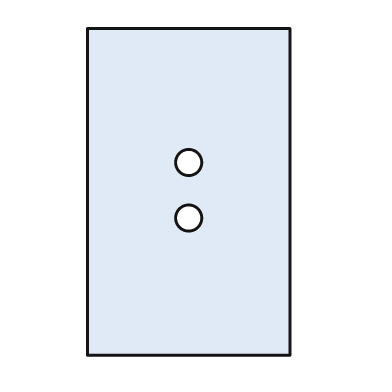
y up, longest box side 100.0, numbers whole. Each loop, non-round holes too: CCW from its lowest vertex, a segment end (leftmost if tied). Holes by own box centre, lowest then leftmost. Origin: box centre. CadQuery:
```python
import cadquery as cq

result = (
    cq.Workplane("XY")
    .moveTo(-31.0, -50.0)
    .lineTo(31.0, -50.0)
    .lineTo(31.0, 50.0)
    .lineTo(-31.0, 50.0)
    .close()
    .moveTo(0.0, -8.0)
    .circle(4.0)
    .moveTo(0.0, 9.0)
    .circle(4.0)
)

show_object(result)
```